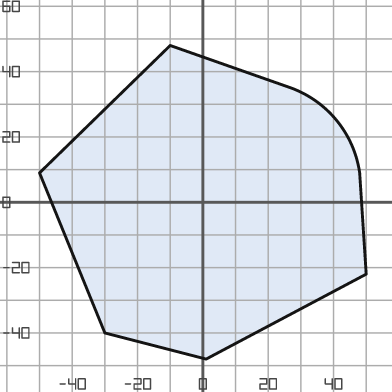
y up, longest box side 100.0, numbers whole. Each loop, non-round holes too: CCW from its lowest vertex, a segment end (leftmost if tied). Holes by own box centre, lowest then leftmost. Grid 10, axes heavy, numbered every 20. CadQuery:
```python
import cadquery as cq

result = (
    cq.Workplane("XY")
    .moveTo(1.0, -48.0)
    .lineTo(50.0, -22.0)
    .lineTo(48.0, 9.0)
    .threePointArc((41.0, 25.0), (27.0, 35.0))
    .lineTo(-10.0, 48.0)
    .lineTo(-50.0, 9.0)
    .lineTo(-30.0, -40.0)
    .close()
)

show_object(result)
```